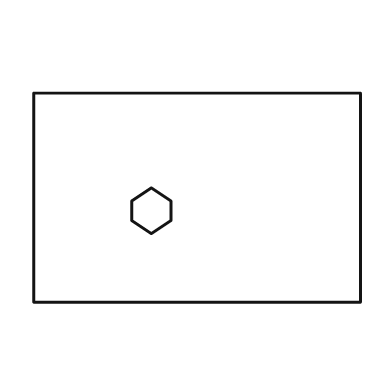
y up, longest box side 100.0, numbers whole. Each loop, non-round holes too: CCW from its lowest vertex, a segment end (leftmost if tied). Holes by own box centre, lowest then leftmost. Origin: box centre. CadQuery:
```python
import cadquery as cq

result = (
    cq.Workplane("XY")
    .moveTo(-50.0, -32.0)
    .lineTo(50.0, -32.0)
    .lineTo(50.0, 32.0)
    .lineTo(-50.0, 32.0)
    .close()
    .moveTo(-14.0, -11.0)
    .lineTo(-8.0, -7.0)
    .lineTo(-8.0, -1.0)
    .lineTo(-14.0, 3.0)
    .lineTo(-20.0, -1.0)
    .lineTo(-20.0, -7.0)
    .close()
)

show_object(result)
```